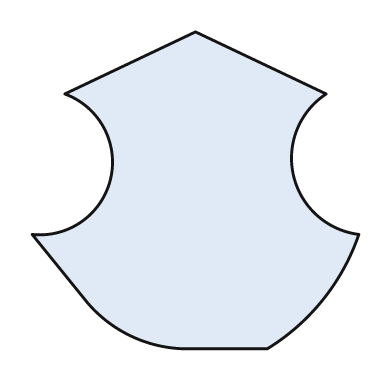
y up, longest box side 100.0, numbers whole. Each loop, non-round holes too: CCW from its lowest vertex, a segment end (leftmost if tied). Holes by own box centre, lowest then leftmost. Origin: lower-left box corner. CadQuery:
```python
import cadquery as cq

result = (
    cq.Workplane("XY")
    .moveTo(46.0, 0.0)
    .lineTo(72.0, 0.0)
    .threePointArc((89.0, 15.0), (100.0, 35.0))
    .threePointArc((80.0, 53.0), (90.0, 78.0))
    .lineTo(50.0, 97.0)
    .lineTo(10.0, 78.0)
    .threePointArc((24.0, 52.0), (0.0, 35.0))
    .lineTo(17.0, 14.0)
    .threePointArc((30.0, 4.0), (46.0, 0.0))
    .close()
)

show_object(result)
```